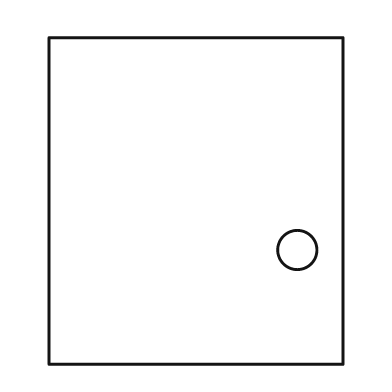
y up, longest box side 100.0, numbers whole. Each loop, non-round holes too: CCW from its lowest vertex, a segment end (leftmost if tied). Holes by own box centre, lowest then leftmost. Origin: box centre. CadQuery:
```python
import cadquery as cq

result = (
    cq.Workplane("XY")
    .moveTo(-45.0, -50.0)
    .lineTo(45.0, -50.0)
    .lineTo(45.0, 50.0)
    .lineTo(-45.0, 50.0)
    .close()
    .moveTo(31.0, -15.0)
    .circle(6.0)
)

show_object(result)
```